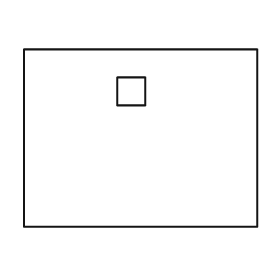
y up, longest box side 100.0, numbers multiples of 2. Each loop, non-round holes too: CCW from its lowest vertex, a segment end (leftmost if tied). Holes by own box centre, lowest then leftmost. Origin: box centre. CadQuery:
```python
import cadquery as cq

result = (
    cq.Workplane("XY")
    .moveTo(-50.0, -38.0)
    .lineTo(50.0, -38.0)
    .lineTo(50.0, 38.0)
    .lineTo(-50.0, 38.0)
    .close()
    .moveTo(-10.0, 14.0)
    .lineTo(2.0, 14.0)
    .lineTo(2.0, 26.0)
    .lineTo(-10.0, 26.0)
    .close()
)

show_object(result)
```